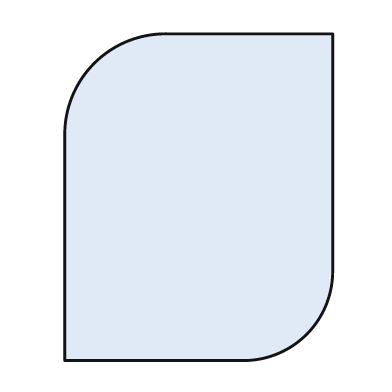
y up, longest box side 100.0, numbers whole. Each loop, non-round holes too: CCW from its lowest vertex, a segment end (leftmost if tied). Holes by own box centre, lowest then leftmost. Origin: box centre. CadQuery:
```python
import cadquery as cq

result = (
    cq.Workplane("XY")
    .moveTo(-41.0, -50.0)
    .lineTo(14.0, -50.0)
    .threePointArc((33.0, -42.0), (41.0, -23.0))
    .lineTo(41.0, 50.0)
    .lineTo(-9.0, 50.0)
    .threePointArc((-32.0, 41.0), (-41.0, 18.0))
    .close()
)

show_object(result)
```